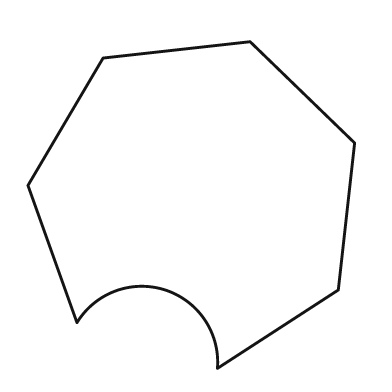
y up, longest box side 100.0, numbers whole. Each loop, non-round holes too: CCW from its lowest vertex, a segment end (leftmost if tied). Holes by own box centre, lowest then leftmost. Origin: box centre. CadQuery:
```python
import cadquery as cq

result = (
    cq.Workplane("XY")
    .moveTo(8.0, -50.0)
    .lineTo(45.0, -26.0)
    .lineTo(50.0, 19.0)
    .lineTo(18.0, 50.0)
    .lineTo(-27.0, 45.0)
    .lineTo(-50.0, 6.0)
    .lineTo(-35.0, -36.0)
    .threePointArc((-8.0, -26.0), (8.0, -50.0))
    .close()
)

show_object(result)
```